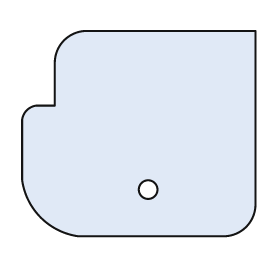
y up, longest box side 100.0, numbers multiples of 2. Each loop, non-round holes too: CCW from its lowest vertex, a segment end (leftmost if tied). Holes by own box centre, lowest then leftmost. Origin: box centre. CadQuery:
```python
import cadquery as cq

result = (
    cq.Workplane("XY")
    .moveTo(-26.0, -44.0)
    .lineTo(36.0, -44.0)
    .threePointArc((46.0, -40.0), (50.0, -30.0))
    .lineTo(50.0, 44.0)
    .lineTo(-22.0, 44.0)
    .threePointArc((-32.0, 40.0), (-36.0, 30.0))
    .lineTo(-36.0, 12.0)
    .lineTo(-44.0, 12.0)
    .threePointArc((-48.0, 10.0), (-50.0, 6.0))
    .lineTo(-50.0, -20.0)
    .threePointArc((-42.0, -36.0), (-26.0, -44.0))
    .close()
    .moveTo(4.0, -24.0)
    .circle(4.0)
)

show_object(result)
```